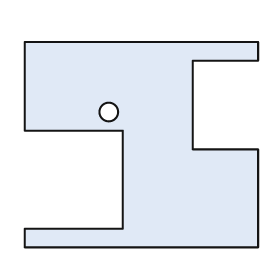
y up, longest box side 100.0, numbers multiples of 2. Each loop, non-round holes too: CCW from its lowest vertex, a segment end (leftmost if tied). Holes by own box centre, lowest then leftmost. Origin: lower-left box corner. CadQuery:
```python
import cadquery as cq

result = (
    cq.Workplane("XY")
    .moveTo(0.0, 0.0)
    .lineTo(100.0, 0.0)
    .lineTo(100.0, 42.0)
    .lineTo(72.0, 42.0)
    .lineTo(72.0, 80.0)
    .lineTo(100.0, 80.0)
    .lineTo(100.0, 88.0)
    .lineTo(0.0, 88.0)
    .lineTo(0.0, 50.0)
    .lineTo(42.0, 50.0)
    .lineTo(42.0, 8.0)
    .lineTo(0.0, 8.0)
    .close()
    .moveTo(36.0, 58.0)
    .circle(4.0)
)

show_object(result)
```